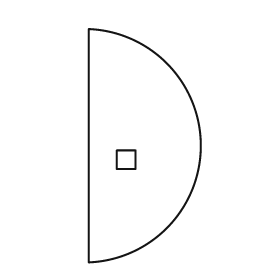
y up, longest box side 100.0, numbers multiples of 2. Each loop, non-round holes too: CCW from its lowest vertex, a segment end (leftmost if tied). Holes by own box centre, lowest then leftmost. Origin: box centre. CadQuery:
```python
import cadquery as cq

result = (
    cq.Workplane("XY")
    .moveTo(-24.0, -50.0)
    .threePointArc((24.0, 0.0), (-24.0, 50.0))
    .close()
    .moveTo(-12.0, -10.0)
    .lineTo(-4.0, -10.0)
    .lineTo(-4.0, -2.0)
    .lineTo(-12.0, -2.0)
    .close()
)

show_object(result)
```